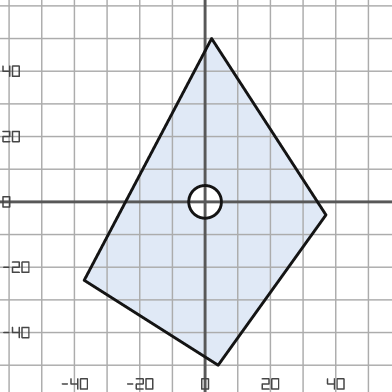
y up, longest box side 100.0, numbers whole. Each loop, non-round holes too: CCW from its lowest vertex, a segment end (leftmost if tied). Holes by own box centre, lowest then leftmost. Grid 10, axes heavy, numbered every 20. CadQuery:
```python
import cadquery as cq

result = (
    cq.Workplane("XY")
    .moveTo(4.0, -50.0)
    .lineTo(37.0, -4.0)
    .lineTo(2.0, 50.0)
    .lineTo(-37.0, -24.0)
    .close()
    .moveTo(0.0, 0.0)
    .circle(5.0)
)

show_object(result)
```